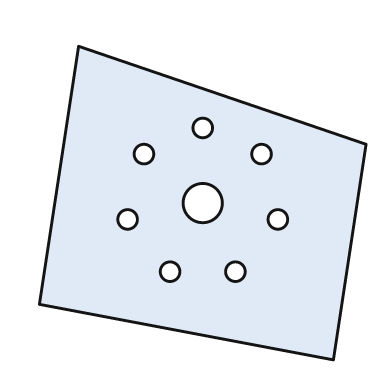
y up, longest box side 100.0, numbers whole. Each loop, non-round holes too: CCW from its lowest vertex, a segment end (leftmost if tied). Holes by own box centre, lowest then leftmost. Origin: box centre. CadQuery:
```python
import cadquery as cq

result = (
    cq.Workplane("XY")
    .moveTo(40.0, -48.0)
    .lineTo(50.0, 18.0)
    .lineTo(-38.0, 48.0)
    .lineTo(-50.0, -31.0)
    .close()
    .moveTo(-10.0, -21.0)
    .circle(3.0)
    .moveTo(10.0, -21.0)
    .circle(3.0)
    .moveTo(-23.0, -5.0)
    .circle(3.0)
    .moveTo(23.0, -5.0)
    .circle(3.0)
    .moveTo(0.0, 0.0)
    .circle(6.0)
    .moveTo(-18.0, 15.0)
    .circle(3.0)
    .moveTo(18.0, 15.0)
    .circle(3.0)
    .moveTo(0.0, 23.0)
    .circle(3.0)
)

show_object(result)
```